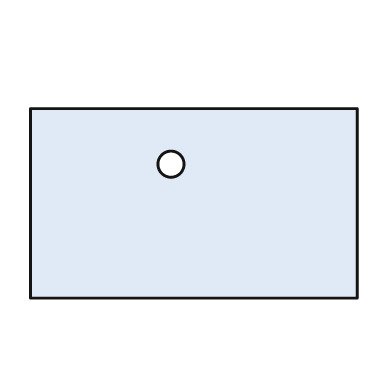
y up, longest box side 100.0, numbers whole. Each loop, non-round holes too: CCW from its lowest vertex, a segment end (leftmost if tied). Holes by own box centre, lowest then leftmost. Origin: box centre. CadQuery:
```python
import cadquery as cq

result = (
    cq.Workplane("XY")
    .moveTo(-50.0, -29.0)
    .lineTo(50.0, -29.0)
    .lineTo(50.0, 29.0)
    .lineTo(-50.0, 29.0)
    .close()
    .moveTo(-7.0, 12.0)
    .circle(4.0)
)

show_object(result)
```